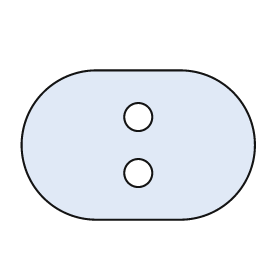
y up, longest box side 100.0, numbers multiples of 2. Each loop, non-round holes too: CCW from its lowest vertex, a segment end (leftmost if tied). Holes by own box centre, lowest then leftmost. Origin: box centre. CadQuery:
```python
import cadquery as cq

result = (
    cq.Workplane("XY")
    .moveTo(-18.0, -32.0)
    .lineTo(18.0, -32.0)
    .threePointArc((50.0, 0.0), (18.0, 32.0))
    .lineTo(-18.0, 32.0)
    .threePointArc((-50.0, 0.0), (-18.0, -32.0))
    .close()
    .moveTo(0.0, -12.0)
    .circle(6.0)
    .moveTo(0.0, 12.0)
    .circle(6.0)
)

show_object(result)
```